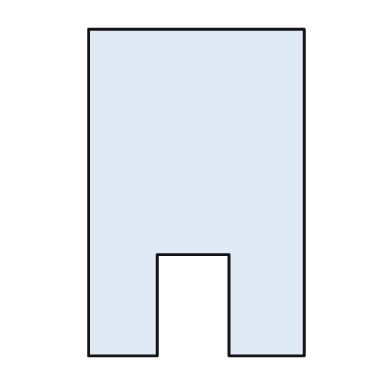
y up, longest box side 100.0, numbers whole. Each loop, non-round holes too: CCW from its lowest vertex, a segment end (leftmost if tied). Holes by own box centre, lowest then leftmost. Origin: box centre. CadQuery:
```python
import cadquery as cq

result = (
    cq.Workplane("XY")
    .moveTo(-33.0, -50.0)
    .lineTo(-12.0, -50.0)
    .lineTo(-12.0, -19.0)
    .lineTo(10.0, -19.0)
    .lineTo(10.0, -50.0)
    .lineTo(33.0, -50.0)
    .lineTo(33.0, 50.0)
    .lineTo(-33.0, 50.0)
    .close()
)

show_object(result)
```